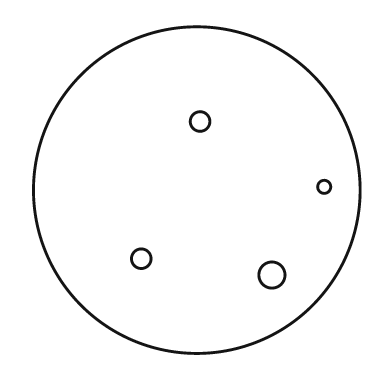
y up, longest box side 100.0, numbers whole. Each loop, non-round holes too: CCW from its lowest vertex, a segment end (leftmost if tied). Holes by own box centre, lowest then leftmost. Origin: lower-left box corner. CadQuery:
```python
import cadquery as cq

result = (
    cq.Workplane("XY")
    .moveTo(50.0, 50.0)
    .circle(50.0)
    .moveTo(73.0, 24.0)
    .circle(4.0)
    .moveTo(33.0, 29.0)
    .circle(3.0)
    .moveTo(89.0, 51.0)
    .circle(2.0)
    .moveTo(51.0, 71.0)
    .circle(3.0)
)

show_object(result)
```